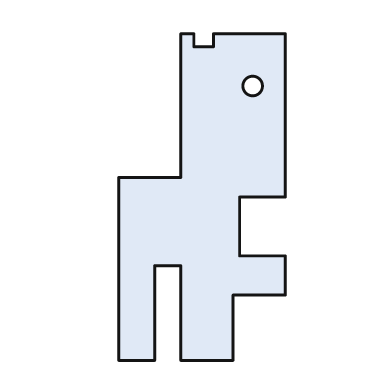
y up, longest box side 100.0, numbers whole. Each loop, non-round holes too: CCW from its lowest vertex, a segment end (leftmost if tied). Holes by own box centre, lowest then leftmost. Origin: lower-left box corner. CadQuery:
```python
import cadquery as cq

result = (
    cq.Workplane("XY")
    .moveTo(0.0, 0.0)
    .lineTo(11.0, 0.0)
    .lineTo(11.0, 29.0)
    .lineTo(19.0, 29.0)
    .lineTo(19.0, 0.0)
    .lineTo(35.0, 0.0)
    .lineTo(35.0, 20.0)
    .lineTo(51.0, 20.0)
    .lineTo(51.0, 32.0)
    .lineTo(37.0, 32.0)
    .lineTo(37.0, 50.0)
    .lineTo(51.0, 50.0)
    .lineTo(51.0, 100.0)
    .lineTo(29.0, 100.0)
    .lineTo(29.0, 96.0)
    .lineTo(23.0, 96.0)
    .lineTo(23.0, 100.0)
    .lineTo(19.0, 100.0)
    .lineTo(19.0, 56.0)
    .lineTo(0.0, 56.0)
    .close()
    .moveTo(41.0, 84.0)
    .circle(3.0)
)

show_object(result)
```